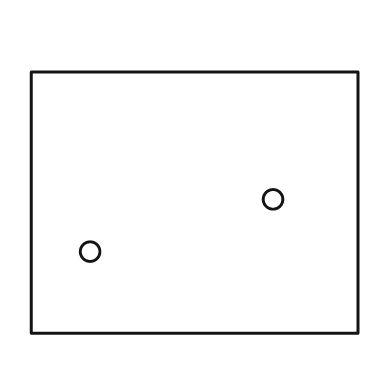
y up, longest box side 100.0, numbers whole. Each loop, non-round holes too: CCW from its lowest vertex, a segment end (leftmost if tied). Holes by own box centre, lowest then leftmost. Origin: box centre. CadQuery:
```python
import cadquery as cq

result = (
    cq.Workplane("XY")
    .moveTo(-50.0, -40.0)
    .lineTo(50.0, -40.0)
    .lineTo(50.0, 40.0)
    .lineTo(-50.0, 40.0)
    .close()
    .moveTo(-32.0, -15.0)
    .circle(3.0)
    .moveTo(24.0, 1.0)
    .circle(3.0)
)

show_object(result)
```